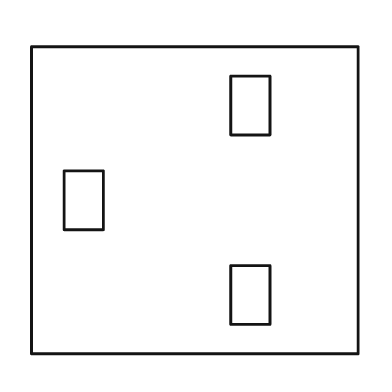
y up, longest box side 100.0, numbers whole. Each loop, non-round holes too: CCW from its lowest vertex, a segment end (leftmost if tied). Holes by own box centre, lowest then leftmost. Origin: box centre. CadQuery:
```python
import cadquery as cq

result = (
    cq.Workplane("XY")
    .moveTo(-50.0, -47.0)
    .lineTo(50.0, -47.0)
    .lineTo(50.0, 47.0)
    .lineTo(-50.0, 47.0)
    .close()
    .moveTo(11.0, -38.0)
    .lineTo(23.0, -38.0)
    .lineTo(23.0, -20.0)
    .lineTo(11.0, -20.0)
    .close()
    .moveTo(-40.0, -9.0)
    .lineTo(-28.0, -9.0)
    .lineTo(-28.0, 9.0)
    .lineTo(-40.0, 9.0)
    .close()
    .moveTo(11.0, 20.0)
    .lineTo(23.0, 20.0)
    .lineTo(23.0, 38.0)
    .lineTo(11.0, 38.0)
    .close()
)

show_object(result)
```